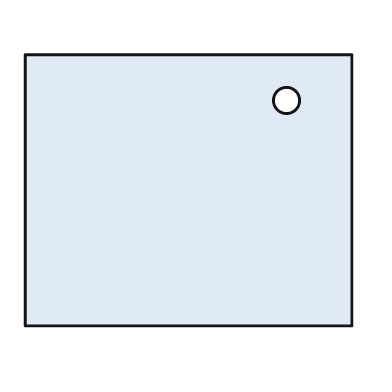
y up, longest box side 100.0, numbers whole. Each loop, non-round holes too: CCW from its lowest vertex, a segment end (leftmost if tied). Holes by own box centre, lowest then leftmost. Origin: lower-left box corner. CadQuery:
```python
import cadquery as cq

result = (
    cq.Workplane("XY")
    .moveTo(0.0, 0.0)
    .lineTo(100.0, 0.0)
    .lineTo(100.0, 83.0)
    .lineTo(0.0, 83.0)
    .close()
    .moveTo(80.0, 69.0)
    .circle(4.0)
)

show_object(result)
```